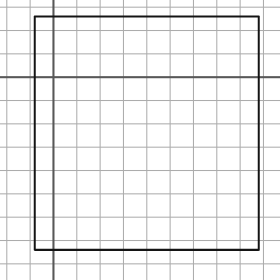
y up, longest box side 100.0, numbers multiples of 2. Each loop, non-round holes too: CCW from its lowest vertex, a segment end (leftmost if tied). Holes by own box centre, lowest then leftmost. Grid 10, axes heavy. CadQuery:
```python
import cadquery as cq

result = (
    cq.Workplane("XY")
    .moveTo(-8.0, -74.0)
    .lineTo(88.0, -74.0)
    .lineTo(88.0, 26.0)
    .lineTo(-8.0, 26.0)
    .close()
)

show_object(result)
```